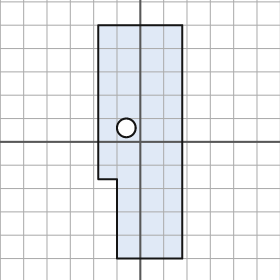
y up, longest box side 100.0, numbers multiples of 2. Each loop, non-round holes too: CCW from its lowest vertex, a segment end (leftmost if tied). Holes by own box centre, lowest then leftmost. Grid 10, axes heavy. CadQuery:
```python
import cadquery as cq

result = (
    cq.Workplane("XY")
    .moveTo(-10.0, -50.0)
    .lineTo(18.0, -50.0)
    .lineTo(18.0, 50.0)
    .lineTo(-18.0, 50.0)
    .lineTo(-18.0, -16.0)
    .lineTo(-10.0, -16.0)
    .close()
    .moveTo(-6.0, 6.0)
    .circle(4.0)
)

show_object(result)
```